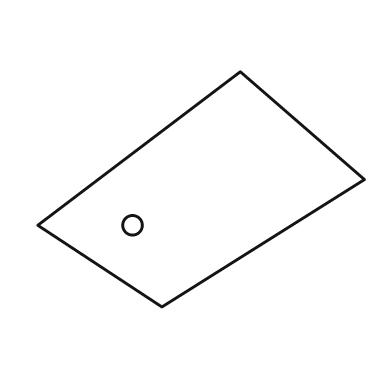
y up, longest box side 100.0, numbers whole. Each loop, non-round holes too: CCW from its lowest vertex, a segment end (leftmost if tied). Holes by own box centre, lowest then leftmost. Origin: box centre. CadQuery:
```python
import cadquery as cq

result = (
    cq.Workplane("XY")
    .moveTo(-12.0, -36.0)
    .lineTo(50.0, 3.0)
    .lineTo(12.0, 36.0)
    .lineTo(-50.0, -11.0)
    .close()
    .moveTo(-21.0, -11.0)
    .circle(3.0)
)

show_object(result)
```